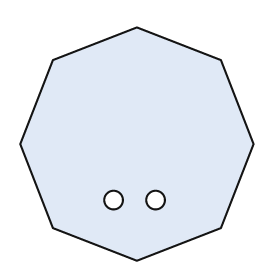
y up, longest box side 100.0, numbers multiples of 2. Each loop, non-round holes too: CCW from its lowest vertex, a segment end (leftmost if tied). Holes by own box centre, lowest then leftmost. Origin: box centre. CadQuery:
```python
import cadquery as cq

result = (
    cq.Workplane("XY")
    .moveTo(0.0, -50.0)
    .lineTo(36.0, -36.0)
    .lineTo(50.0, 0.0)
    .lineTo(36.0, 36.0)
    .lineTo(0.0, 50.0)
    .lineTo(-36.0, 36.0)
    .lineTo(-50.0, 0.0)
    .lineTo(-36.0, -36.0)
    .close()
    .moveTo(-10.0, -24.0)
    .circle(4.0)
    .moveTo(8.0, -24.0)
    .circle(4.0)
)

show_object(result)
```